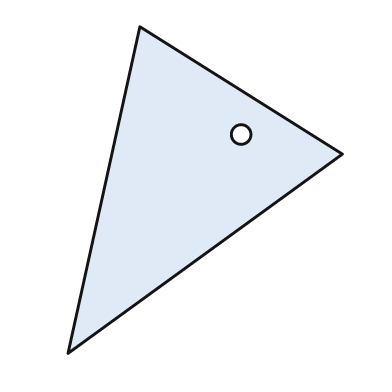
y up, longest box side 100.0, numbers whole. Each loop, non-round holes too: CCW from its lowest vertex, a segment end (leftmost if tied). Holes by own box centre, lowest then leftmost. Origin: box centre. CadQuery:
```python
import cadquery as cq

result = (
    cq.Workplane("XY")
    .moveTo(-42.0, -50.0)
    .lineTo(42.0, 11.0)
    .lineTo(-20.0, 50.0)
    .close()
    .moveTo(11.0, 17.0)
    .circle(3.0)
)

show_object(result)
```